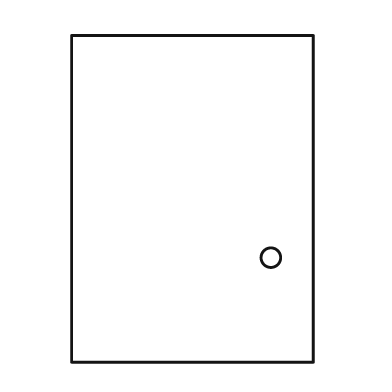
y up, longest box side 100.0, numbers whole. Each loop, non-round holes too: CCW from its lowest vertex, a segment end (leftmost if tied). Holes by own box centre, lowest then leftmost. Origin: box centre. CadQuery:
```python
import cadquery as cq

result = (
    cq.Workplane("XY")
    .moveTo(-37.0, -50.0)
    .lineTo(37.0, -50.0)
    .lineTo(37.0, 50.0)
    .lineTo(-37.0, 50.0)
    .close()
    .moveTo(24.0, -18.0)
    .circle(3.0)
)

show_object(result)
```